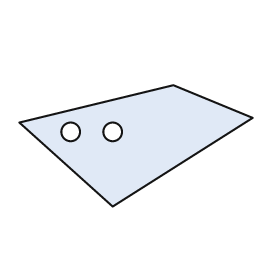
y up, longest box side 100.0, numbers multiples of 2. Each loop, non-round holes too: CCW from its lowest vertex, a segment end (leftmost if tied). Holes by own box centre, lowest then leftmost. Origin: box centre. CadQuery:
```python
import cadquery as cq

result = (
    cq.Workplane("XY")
    .moveTo(-10.0, -26.0)
    .lineTo(50.0, 12.0)
    .lineTo(16.0, 26.0)
    .lineTo(-50.0, 10.0)
    .close()
    .moveTo(-28.0, 6.0)
    .circle(4.0)
    .moveTo(-10.0, 6.0)
    .circle(4.0)
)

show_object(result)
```